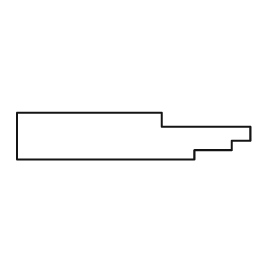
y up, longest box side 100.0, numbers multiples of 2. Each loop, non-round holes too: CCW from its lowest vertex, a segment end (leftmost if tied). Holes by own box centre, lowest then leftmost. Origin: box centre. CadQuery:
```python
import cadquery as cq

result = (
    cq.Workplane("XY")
    .moveTo(-50.0, -10.0)
    .lineTo(26.0, -10.0)
    .lineTo(26.0, -6.0)
    .lineTo(42.0, -6.0)
    .lineTo(42.0, -2.0)
    .lineTo(50.0, -2.0)
    .lineTo(50.0, 4.0)
    .lineTo(12.0, 4.0)
    .lineTo(12.0, 10.0)
    .lineTo(-50.0, 10.0)
    .close()
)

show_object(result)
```